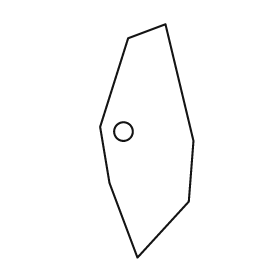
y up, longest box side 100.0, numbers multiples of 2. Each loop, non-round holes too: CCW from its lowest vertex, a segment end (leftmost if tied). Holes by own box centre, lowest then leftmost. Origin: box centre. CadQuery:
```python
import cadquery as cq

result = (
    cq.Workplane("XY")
    .moveTo(-4.0, -50.0)
    .lineTo(18.0, -26.0)
    .lineTo(20.0, 0.0)
    .lineTo(8.0, 50.0)
    .lineTo(-8.0, 44.0)
    .lineTo(-20.0, 6.0)
    .lineTo(-16.0, -18.0)
    .close()
    .moveTo(-10.0, 4.0)
    .circle(4.0)
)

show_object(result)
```